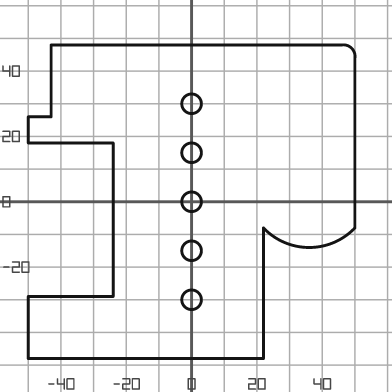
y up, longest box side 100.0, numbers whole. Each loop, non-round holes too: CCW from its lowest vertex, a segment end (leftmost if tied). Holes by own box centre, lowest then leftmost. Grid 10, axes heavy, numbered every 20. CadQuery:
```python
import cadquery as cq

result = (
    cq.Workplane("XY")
    .moveTo(-50.0, -48.0)
    .lineTo(22.0, -48.0)
    .lineTo(22.0, -8.0)
    .threePointArc((36.0, -14.0), (50.0, -8.0))
    .lineTo(50.0, 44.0)
    .threePointArc((49.0, 47.0), (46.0, 48.0))
    .lineTo(-43.0, 48.0)
    .lineTo(-43.0, 26.0)
    .lineTo(-50.0, 26.0)
    .lineTo(-50.0, 18.0)
    .lineTo(-24.0, 18.0)
    .lineTo(-24.0, -29.0)
    .lineTo(-50.0, -29.0)
    .close()
    .moveTo(0.0, -30.0)
    .circle(3.0)
    .moveTo(0.0, -15.0)
    .circle(3.0)
    .moveTo(0.0, 0.0)
    .circle(3.0)
    .moveTo(0.0, 15.0)
    .circle(3.0)
    .moveTo(0.0, 30.0)
    .circle(3.0)
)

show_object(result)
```